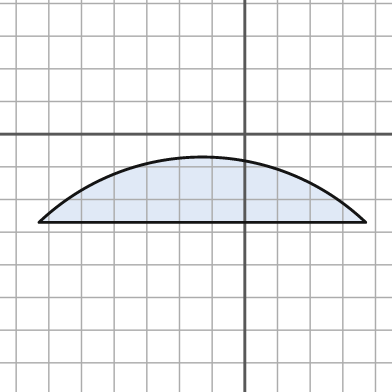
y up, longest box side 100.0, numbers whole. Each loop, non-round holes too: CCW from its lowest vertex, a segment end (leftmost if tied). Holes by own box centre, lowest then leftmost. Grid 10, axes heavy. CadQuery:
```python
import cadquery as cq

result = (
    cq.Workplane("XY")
    .moveTo(-63.0, -27.0)
    .lineTo(37.0, -27.0)
    .threePointArc((-13.0, -7.0), (-63.0, -27.0))
    .close()
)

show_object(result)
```